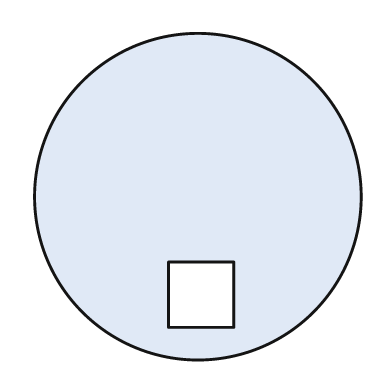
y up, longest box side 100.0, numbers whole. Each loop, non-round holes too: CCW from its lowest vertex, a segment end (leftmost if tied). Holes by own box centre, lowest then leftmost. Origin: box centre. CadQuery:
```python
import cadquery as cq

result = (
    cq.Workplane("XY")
    .moveTo(0.0, 0.0)
    .circle(50.0)
    .moveTo(-9.0, -40.0)
    .lineTo(11.0, -40.0)
    .lineTo(11.0, -20.0)
    .lineTo(-9.0, -20.0)
    .close()
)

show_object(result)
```